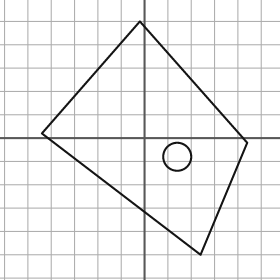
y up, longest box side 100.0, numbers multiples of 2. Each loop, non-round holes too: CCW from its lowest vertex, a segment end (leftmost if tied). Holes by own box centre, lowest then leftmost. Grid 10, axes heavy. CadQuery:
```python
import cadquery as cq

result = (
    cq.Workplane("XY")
    .moveTo(24.0, -50.0)
    .lineTo(44.0, -2.0)
    .lineTo(-2.0, 50.0)
    .lineTo(-44.0, 2.0)
    .close()
    .moveTo(14.0, -8.0)
    .circle(6.0)
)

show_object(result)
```